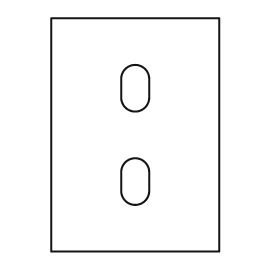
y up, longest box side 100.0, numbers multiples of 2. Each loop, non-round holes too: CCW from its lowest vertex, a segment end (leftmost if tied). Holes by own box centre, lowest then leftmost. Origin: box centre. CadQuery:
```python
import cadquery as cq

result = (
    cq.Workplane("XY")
    .moveTo(-36.0, -50.0)
    .lineTo(36.0, -50.0)
    .lineTo(36.0, 50.0)
    .lineTo(-36.0, 50.0)
    .close()
    .moveTo(-6.0, -24.0)
    .threePointArc((0.0, -30.0), (6.0, -24.0))
    .lineTo(6.0, -16.0)
    .threePointArc((0.0, -10.0), (-6.0, -16.0))
    .close()
    .moveTo(-6.0, 16.0)
    .threePointArc((0.0, 10.0), (6.0, 16.0))
    .lineTo(6.0, 24.0)
    .threePointArc((0.0, 30.0), (-6.0, 24.0))
    .close()
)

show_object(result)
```